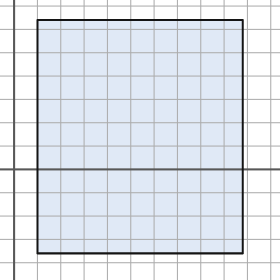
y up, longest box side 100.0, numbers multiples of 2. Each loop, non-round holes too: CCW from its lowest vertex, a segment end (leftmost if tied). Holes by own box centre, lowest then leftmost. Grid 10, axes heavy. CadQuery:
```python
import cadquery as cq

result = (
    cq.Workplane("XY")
    .moveTo(10.0, -36.0)
    .lineTo(98.0, -36.0)
    .lineTo(98.0, 64.0)
    .lineTo(10.0, 64.0)
    .close()
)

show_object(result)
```